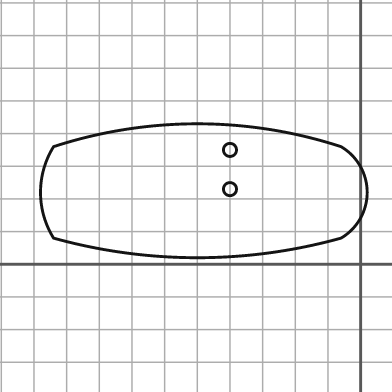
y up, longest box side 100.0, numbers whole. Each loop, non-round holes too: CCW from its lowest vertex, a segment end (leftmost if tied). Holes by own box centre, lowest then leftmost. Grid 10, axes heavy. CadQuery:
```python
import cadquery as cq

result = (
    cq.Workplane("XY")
    .moveTo(-94.0, 8.0)
    .threePointArc((-50.0, 2.0), (-6.0, 8.0))
    .threePointArc((2.0, 22.0), (-6.0, 36.0))
    .threePointArc((-50.0, 43.0), (-94.0, 36.0))
    .threePointArc((-98.0, 22.0), (-94.0, 8.0))
    .close()
    .moveTo(-40.0, 23.0)
    .circle(2.0)
    .moveTo(-40.0, 35.0)
    .circle(2.0)
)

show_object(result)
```